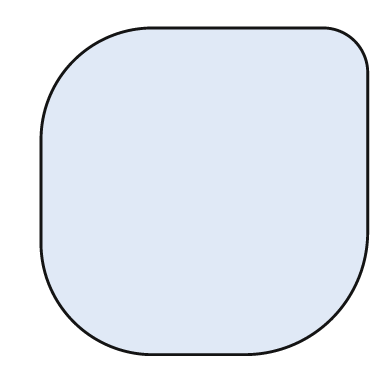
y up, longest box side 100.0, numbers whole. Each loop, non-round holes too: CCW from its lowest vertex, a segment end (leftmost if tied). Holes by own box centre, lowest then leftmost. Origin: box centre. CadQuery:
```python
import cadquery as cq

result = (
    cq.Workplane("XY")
    .moveTo(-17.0, -50.0)
    .lineTo(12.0, -50.0)
    .threePointArc((39.0, -39.0), (50.0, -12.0))
    .lineTo(50.0, 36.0)
    .threePointArc((46.0, 46.0), (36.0, 50.0))
    .lineTo(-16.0, 50.0)
    .threePointArc((-40.0, 40.0), (-50.0, 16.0))
    .lineTo(-50.0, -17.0)
    .threePointArc((-40.0, -40.0), (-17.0, -50.0))
    .close()
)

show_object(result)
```